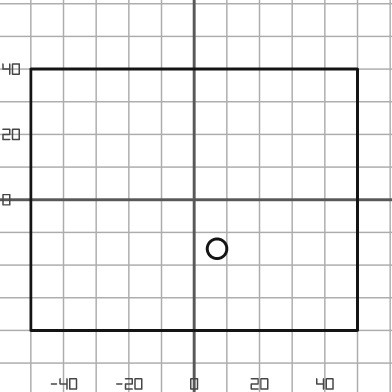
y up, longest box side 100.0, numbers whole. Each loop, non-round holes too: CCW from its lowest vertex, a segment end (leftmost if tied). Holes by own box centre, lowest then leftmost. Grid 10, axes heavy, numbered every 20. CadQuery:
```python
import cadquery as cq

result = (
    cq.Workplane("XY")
    .moveTo(-50.0, -40.0)
    .lineTo(50.0, -40.0)
    .lineTo(50.0, 40.0)
    .lineTo(-50.0, 40.0)
    .close()
    .moveTo(7.0, -15.0)
    .circle(3.0)
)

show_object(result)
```